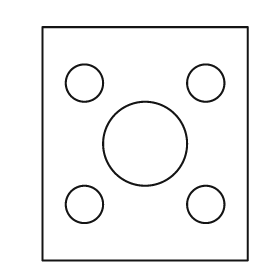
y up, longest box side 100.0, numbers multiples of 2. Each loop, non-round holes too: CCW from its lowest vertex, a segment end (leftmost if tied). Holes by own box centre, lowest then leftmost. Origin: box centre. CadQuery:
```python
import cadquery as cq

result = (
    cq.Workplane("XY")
    .moveTo(-44.0, -50.0)
    .lineTo(44.0, -50.0)
    .lineTo(44.0, 50.0)
    .lineTo(-44.0, 50.0)
    .close()
    .moveTo(-26.0, -26.0)
    .circle(8.0)
    .moveTo(26.0, -26.0)
    .circle(8.0)
    .moveTo(0.0, 0.0)
    .circle(18.0)
    .moveTo(-26.0, 26.0)
    .circle(8.0)
    .moveTo(26.0, 26.0)
    .circle(8.0)
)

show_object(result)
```